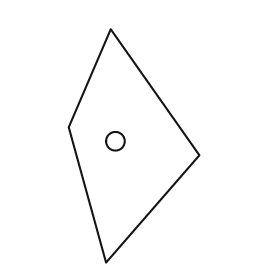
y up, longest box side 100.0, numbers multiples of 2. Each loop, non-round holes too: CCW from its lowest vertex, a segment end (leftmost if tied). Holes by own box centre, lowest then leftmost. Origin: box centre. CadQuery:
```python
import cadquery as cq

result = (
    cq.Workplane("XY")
    .moveTo(-12.0, -50.0)
    .lineTo(28.0, -4.0)
    .lineTo(-10.0, 50.0)
    .lineTo(-28.0, 8.0)
    .close()
    .moveTo(-8.0, 2.0)
    .circle(4.0)
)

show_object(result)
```